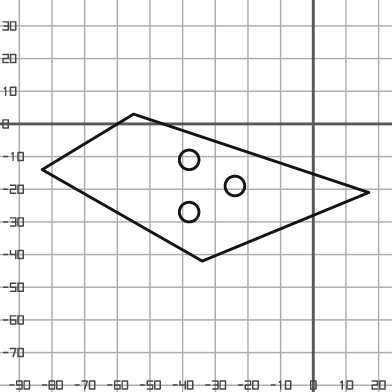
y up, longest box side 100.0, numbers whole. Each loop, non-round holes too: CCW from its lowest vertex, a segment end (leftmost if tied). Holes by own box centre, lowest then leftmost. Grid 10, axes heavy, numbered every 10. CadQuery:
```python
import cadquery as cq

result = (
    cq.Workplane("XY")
    .moveTo(-34.0, -42.0)
    .lineTo(17.0, -21.0)
    .lineTo(-55.0, 3.0)
    .lineTo(-83.0, -14.0)
    .close()
    .moveTo(-38.0, -27.0)
    .circle(3.0)
    .moveTo(-24.0, -19.0)
    .circle(3.0)
    .moveTo(-38.0, -11.0)
    .circle(3.0)
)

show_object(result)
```